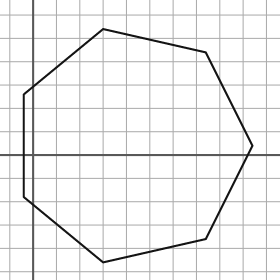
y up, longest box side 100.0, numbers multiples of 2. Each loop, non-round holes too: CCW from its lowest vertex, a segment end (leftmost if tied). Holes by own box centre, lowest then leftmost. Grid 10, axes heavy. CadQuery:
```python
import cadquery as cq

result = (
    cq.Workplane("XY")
    .moveTo(30.0, -46.0)
    .lineTo(74.0, -36.0)
    .lineTo(94.0, 4.0)
    .lineTo(74.0, 44.0)
    .lineTo(30.0, 54.0)
    .lineTo(-4.0, 26.0)
    .lineTo(-4.0, -18.0)
    .close()
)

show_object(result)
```